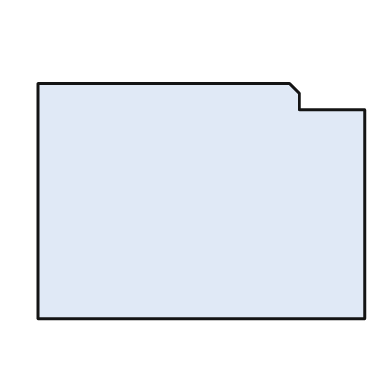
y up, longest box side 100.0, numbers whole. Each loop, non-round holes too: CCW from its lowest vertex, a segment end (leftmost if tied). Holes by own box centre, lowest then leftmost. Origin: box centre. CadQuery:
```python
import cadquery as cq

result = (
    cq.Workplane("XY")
    .moveTo(-50.0, -36.0)
    .lineTo(50.0, -36.0)
    .lineTo(50.0, 28.0)
    .lineTo(30.0, 28.0)
    .lineTo(30.0, 33.0)
    .lineTo(27.0, 36.0)
    .lineTo(-50.0, 36.0)
    .close()
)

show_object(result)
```